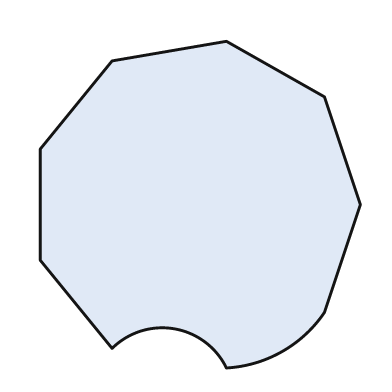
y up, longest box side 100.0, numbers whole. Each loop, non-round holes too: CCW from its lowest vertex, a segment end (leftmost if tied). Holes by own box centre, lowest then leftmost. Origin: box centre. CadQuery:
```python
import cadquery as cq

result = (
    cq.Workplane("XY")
    .moveTo(8.0, -50.0)
    .threePointArc((25.0, -45.0), (38.0, -33.0))
    .lineTo(49.0, 0.0)
    .lineTo(38.0, 33.0)
    .lineTo(8.0, 50.0)
    .lineTo(-27.0, 44.0)
    .lineTo(-49.0, 17.0)
    .lineTo(-49.0, -17.0)
    .lineTo(-27.0, -44.0)
    .threePointArc((-8.0, -38.0), (8.0, -50.0))
    .close()
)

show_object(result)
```